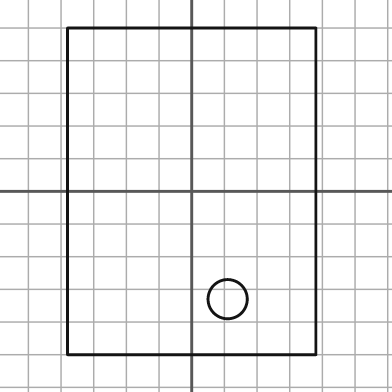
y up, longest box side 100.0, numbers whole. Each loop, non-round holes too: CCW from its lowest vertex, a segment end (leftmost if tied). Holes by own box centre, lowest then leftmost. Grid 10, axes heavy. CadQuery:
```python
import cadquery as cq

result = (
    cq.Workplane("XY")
    .moveTo(-38.0, -50.0)
    .lineTo(38.0, -50.0)
    .lineTo(38.0, 50.0)
    .lineTo(-38.0, 50.0)
    .close()
    .moveTo(11.0, -33.0)
    .circle(6.0)
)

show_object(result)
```